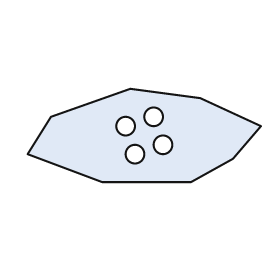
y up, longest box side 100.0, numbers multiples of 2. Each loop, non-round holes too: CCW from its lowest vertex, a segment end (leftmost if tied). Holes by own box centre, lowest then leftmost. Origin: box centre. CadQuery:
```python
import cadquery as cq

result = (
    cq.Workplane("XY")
    .moveTo(-18.0, -20.0)
    .lineTo(20.0, -20.0)
    .lineTo(38.0, -10.0)
    .lineTo(50.0, 4.0)
    .lineTo(24.0, 16.0)
    .lineTo(-6.0, 20.0)
    .lineTo(-40.0, 8.0)
    .lineTo(-50.0, -8.0)
    .close()
    .moveTo(-4.0, -8.0)
    .circle(4.0)
    .moveTo(8.0, -4.0)
    .circle(4.0)
    .moveTo(-8.0, 4.0)
    .circle(4.0)
    .moveTo(4.0, 8.0)
    .circle(4.0)
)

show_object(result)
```